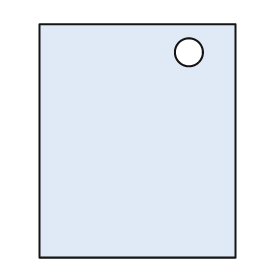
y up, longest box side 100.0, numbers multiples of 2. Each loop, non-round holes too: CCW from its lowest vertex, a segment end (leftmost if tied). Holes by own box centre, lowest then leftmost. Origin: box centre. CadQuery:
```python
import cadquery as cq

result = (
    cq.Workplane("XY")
    .moveTo(-42.0, -50.0)
    .lineTo(42.0, -50.0)
    .lineTo(42.0, 50.0)
    .lineTo(-42.0, 50.0)
    .close()
    .moveTo(22.0, 38.0)
    .circle(6.0)
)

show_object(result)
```